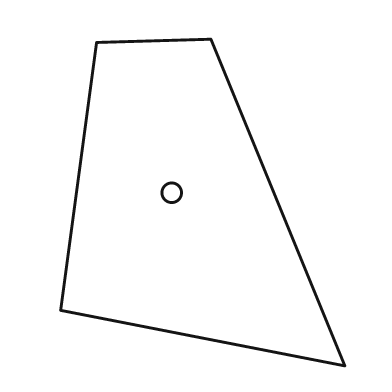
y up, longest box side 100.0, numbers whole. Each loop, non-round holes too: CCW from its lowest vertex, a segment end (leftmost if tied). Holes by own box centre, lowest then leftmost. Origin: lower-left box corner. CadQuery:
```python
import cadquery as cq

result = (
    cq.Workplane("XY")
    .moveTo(87.0, 0.0)
    .lineTo(46.0, 100.0)
    .lineTo(11.0, 99.0)
    .lineTo(0.0, 17.0)
    .close()
    .moveTo(34.0, 53.0)
    .circle(3.0)
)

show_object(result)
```